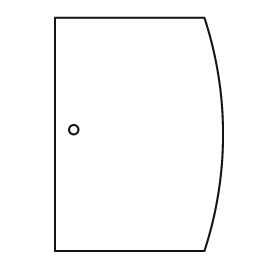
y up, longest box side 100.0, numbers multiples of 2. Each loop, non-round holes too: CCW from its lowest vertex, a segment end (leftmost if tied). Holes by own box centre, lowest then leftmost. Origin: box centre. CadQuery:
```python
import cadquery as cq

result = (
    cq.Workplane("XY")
    .moveTo(-36.0, -50.0)
    .lineTo(28.0, -50.0)
    .threePointArc((36.0, 0.0), (28.0, 50.0))
    .lineTo(-36.0, 50.0)
    .close()
    .moveTo(-28.0, 2.0)
    .circle(2.0)
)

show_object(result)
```